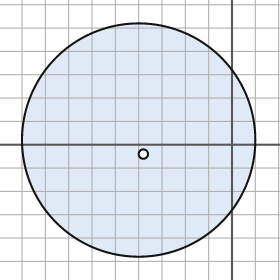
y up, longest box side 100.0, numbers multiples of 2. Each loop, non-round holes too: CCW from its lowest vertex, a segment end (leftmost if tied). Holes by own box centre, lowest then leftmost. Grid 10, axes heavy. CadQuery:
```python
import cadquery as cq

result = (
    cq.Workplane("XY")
    .moveTo(-40.0, 2.0)
    .circle(50.0)
    .moveTo(-38.0, -4.0)
    .circle(2.0)
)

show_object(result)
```